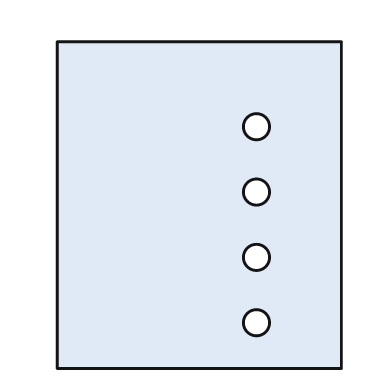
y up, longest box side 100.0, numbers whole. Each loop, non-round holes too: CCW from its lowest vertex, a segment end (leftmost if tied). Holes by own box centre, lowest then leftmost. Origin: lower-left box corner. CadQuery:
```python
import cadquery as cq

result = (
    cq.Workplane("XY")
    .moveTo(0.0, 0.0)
    .lineTo(87.0, 0.0)
    .lineTo(87.0, 100.0)
    .lineTo(0.0, 100.0)
    .close()
    .moveTo(61.0, 14.0)
    .circle(4.0)
    .moveTo(61.0, 34.0)
    .circle(4.0)
    .moveTo(61.0, 54.0)
    .circle(4.0)
    .moveTo(61.0, 74.0)
    .circle(4.0)
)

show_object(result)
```